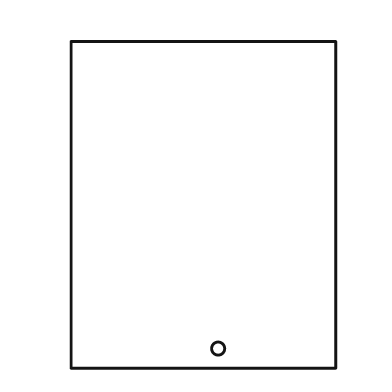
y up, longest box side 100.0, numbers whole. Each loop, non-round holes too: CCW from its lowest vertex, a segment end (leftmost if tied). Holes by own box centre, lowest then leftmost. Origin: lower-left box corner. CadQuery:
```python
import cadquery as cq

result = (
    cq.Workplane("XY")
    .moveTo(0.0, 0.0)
    .lineTo(81.0, 0.0)
    .lineTo(81.0, 100.0)
    .lineTo(0.0, 100.0)
    .close()
    .moveTo(45.0, 6.0)
    .circle(2.0)
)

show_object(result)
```